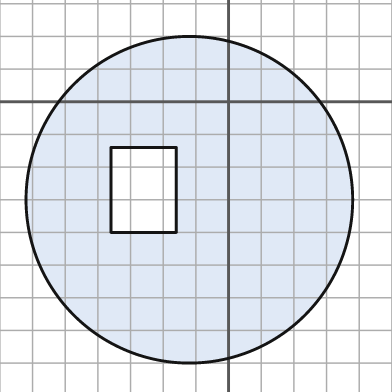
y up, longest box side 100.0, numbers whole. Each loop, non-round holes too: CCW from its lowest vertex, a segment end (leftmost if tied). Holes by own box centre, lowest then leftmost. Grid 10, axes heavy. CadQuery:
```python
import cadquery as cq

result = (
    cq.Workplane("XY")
    .moveTo(-12.0, -30.0)
    .circle(50.0)
    .moveTo(-36.0, -40.0)
    .lineTo(-16.0, -40.0)
    .lineTo(-16.0, -14.0)
    .lineTo(-36.0, -14.0)
    .close()
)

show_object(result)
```